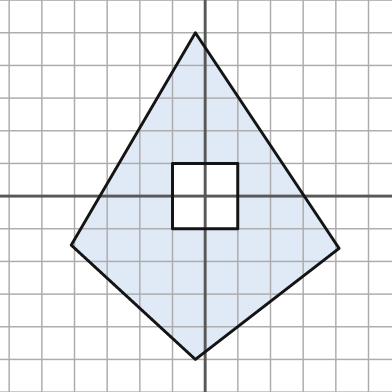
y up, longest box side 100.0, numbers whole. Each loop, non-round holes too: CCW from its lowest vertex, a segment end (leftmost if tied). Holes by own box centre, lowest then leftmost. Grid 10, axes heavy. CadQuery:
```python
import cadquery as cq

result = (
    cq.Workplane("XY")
    .moveTo(-3.0, -50.0)
    .lineTo(41.0, -16.0)
    .lineTo(-3.0, 50.0)
    .lineTo(-41.0, -15.0)
    .close()
    .moveTo(-10.0, -10.0)
    .lineTo(10.0, -10.0)
    .lineTo(10.0, 10.0)
    .lineTo(-10.0, 10.0)
    .close()
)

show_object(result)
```